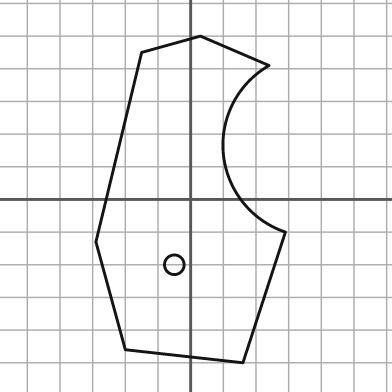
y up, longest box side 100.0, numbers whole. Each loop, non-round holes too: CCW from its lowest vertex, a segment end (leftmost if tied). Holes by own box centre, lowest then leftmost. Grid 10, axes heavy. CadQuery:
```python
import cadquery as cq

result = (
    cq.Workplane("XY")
    .moveTo(16.0, -50.0)
    .lineTo(29.0, -10.0)
    .threePointArc((10.0, 14.0), (24.0, 41.0))
    .lineTo(3.0, 50.0)
    .lineTo(-15.0, 45.0)
    .lineTo(-29.0, -13.0)
    .lineTo(-20.0, -46.0)
    .close()
    .moveTo(-5.0, -20.0)
    .circle(3.0)
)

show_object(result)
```